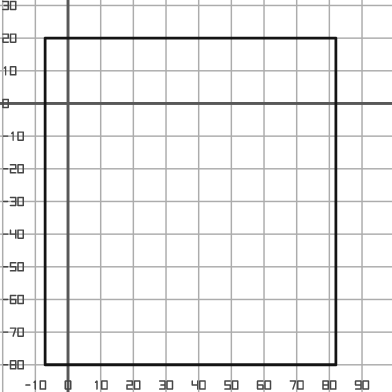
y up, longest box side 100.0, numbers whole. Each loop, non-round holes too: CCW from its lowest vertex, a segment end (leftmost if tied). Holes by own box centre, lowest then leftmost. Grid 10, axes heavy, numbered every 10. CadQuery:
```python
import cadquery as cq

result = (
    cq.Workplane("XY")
    .moveTo(-7.0, -80.0)
    .lineTo(82.0, -80.0)
    .lineTo(82.0, 20.0)
    .lineTo(-7.0, 20.0)
    .close()
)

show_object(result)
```